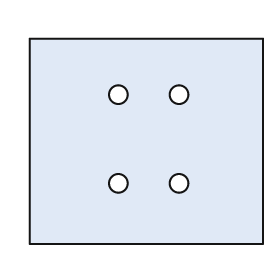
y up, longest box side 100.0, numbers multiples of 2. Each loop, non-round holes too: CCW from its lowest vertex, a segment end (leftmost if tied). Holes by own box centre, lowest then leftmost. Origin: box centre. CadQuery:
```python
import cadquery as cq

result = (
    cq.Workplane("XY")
    .moveTo(-50.0, -44.0)
    .lineTo(50.0, -44.0)
    .lineTo(50.0, 44.0)
    .lineTo(-50.0, 44.0)
    .close()
    .moveTo(-12.0, -18.0)
    .circle(4.0)
    .moveTo(14.0, -18.0)
    .circle(4.0)
    .moveTo(-12.0, 20.0)
    .circle(4.0)
    .moveTo(14.0, 20.0)
    .circle(4.0)
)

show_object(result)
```